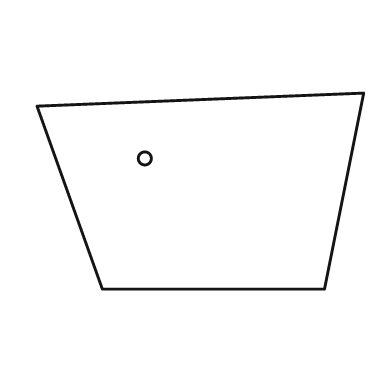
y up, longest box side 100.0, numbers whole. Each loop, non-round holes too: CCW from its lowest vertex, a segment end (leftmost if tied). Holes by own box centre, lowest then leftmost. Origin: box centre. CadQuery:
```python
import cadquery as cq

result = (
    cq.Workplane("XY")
    .moveTo(-30.0, -30.0)
    .lineTo(38.0, -30.0)
    .lineTo(50.0, 30.0)
    .lineTo(-50.0, 26.0)
    .close()
    .moveTo(-17.0, 10.0)
    .circle(2.0)
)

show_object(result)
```